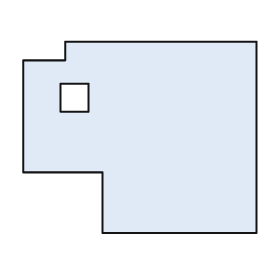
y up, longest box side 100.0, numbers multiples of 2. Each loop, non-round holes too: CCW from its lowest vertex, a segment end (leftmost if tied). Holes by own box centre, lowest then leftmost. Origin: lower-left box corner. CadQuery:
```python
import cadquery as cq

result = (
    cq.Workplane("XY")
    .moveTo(34.0, 0.0)
    .lineTo(100.0, 0.0)
    .lineTo(100.0, 82.0)
    .lineTo(18.0, 82.0)
    .lineTo(18.0, 74.0)
    .lineTo(0.0, 74.0)
    .lineTo(0.0, 26.0)
    .lineTo(34.0, 26.0)
    .close()
    .moveTo(16.0, 52.0)
    .lineTo(28.0, 52.0)
    .lineTo(28.0, 64.0)
    .lineTo(16.0, 64.0)
    .close()
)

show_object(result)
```